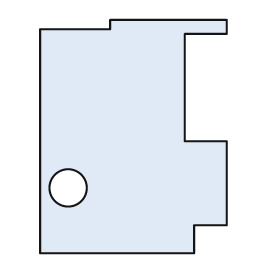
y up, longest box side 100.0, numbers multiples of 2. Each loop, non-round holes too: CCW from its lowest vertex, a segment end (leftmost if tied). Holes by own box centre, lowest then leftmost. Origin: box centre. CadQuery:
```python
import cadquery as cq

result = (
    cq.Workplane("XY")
    .moveTo(-40.0, -50.0)
    .lineTo(26.0, -50.0)
    .lineTo(26.0, -38.0)
    .lineTo(40.0, -38.0)
    .lineTo(40.0, -2.0)
    .lineTo(22.0, -2.0)
    .lineTo(22.0, 44.0)
    .lineTo(40.0, 44.0)
    .lineTo(40.0, 50.0)
    .lineTo(-10.0, 50.0)
    .lineTo(-10.0, 46.0)
    .lineTo(-40.0, 46.0)
    .close()
    .moveTo(-28.0, -22.0)
    .circle(8.0)
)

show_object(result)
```